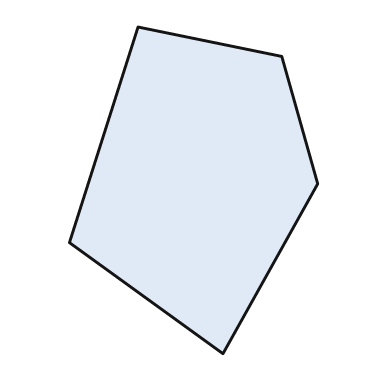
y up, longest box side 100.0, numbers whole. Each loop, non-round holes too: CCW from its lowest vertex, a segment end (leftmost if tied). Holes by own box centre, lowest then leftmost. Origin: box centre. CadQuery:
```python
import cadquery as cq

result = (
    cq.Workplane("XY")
    .moveTo(9.0, -50.0)
    .lineTo(38.0, 2.0)
    .lineTo(27.0, 41.0)
    .lineTo(-17.0, 50.0)
    .lineTo(-38.0, -16.0)
    .close()
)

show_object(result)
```